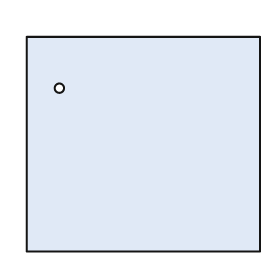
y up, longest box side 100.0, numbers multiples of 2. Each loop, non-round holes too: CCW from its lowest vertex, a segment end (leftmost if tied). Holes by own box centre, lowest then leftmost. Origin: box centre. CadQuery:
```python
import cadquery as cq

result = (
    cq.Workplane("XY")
    .moveTo(-50.0, -46.0)
    .lineTo(50.0, -46.0)
    .lineTo(50.0, 46.0)
    .lineTo(-50.0, 46.0)
    .close()
    .moveTo(-36.0, 24.0)
    .circle(2.0)
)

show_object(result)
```